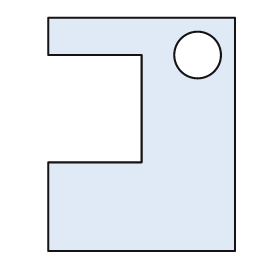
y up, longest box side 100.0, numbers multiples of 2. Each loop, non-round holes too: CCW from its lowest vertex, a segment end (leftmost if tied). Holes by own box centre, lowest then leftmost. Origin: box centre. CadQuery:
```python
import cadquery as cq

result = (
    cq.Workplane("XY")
    .moveTo(-40.0, -50.0)
    .lineTo(40.0, -50.0)
    .lineTo(40.0, 50.0)
    .lineTo(-40.0, 50.0)
    .lineTo(-40.0, 34.0)
    .lineTo(0.0, 34.0)
    .lineTo(0.0, -12.0)
    .lineTo(-40.0, -12.0)
    .close()
    .moveTo(24.0, 34.0)
    .circle(10.0)
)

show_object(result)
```